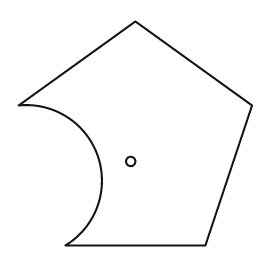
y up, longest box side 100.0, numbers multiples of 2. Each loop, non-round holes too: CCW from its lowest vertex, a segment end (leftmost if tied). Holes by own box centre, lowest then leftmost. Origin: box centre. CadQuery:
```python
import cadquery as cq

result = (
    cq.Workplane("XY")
    .moveTo(-30.0, -48.0)
    .lineTo(30.0, -48.0)
    .lineTo(50.0, 12.0)
    .lineTo(0.0, 48.0)
    .lineTo(-50.0, 12.0)
    .threePointArc((-16.0, -10.0), (-30.0, -48.0))
    .close()
    .moveTo(-2.0, -12.0)
    .circle(2.0)
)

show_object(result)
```